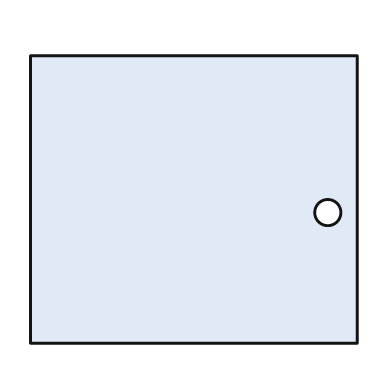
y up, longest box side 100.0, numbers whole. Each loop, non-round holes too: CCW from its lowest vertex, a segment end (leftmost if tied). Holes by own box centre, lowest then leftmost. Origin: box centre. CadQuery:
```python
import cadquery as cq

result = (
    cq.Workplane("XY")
    .moveTo(-50.0, -44.0)
    .lineTo(50.0, -44.0)
    .lineTo(50.0, 44.0)
    .lineTo(-50.0, 44.0)
    .close()
    .moveTo(41.0, -4.0)
    .circle(4.0)
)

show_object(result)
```